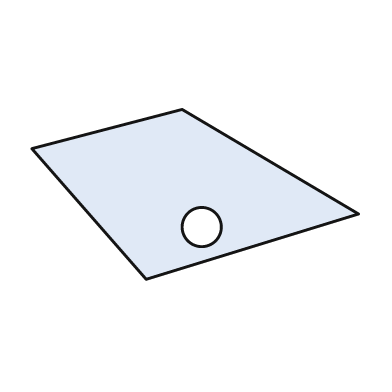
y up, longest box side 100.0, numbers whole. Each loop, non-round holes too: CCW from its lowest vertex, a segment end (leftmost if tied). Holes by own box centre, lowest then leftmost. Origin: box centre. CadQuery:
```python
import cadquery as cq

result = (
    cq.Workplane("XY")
    .moveTo(-15.0, -26.0)
    .lineTo(50.0, -6.0)
    .lineTo(-4.0, 26.0)
    .lineTo(-50.0, 14.0)
    .close()
    .moveTo(2.0, -10.0)
    .circle(6.0)
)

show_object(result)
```